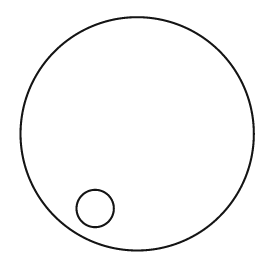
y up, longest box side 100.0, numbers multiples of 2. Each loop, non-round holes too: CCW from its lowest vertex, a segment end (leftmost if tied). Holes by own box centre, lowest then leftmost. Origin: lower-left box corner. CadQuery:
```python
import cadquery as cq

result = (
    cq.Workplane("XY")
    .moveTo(50.0, 50.0)
    .circle(50.0)
    .moveTo(32.0, 18.0)
    .circle(8.0)
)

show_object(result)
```